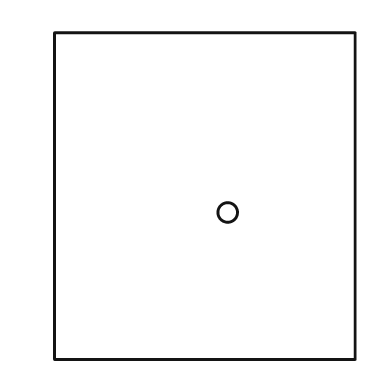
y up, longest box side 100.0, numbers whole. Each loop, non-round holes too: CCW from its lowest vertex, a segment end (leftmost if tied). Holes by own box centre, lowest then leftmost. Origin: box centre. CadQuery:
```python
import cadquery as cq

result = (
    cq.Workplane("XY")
    .moveTo(-46.0, -50.0)
    .lineTo(46.0, -50.0)
    .lineTo(46.0, 50.0)
    .lineTo(-46.0, 50.0)
    .close()
    .moveTo(7.0, -5.0)
    .circle(3.0)
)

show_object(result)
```